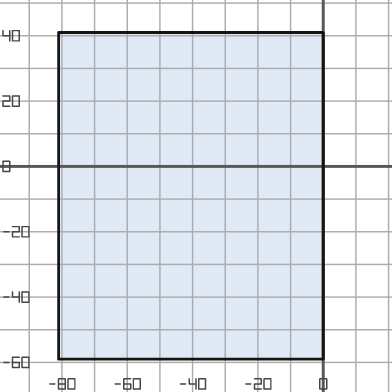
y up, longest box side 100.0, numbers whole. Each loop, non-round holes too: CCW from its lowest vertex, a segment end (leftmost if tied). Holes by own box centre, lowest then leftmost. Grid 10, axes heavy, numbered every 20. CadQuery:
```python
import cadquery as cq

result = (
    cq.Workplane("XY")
    .moveTo(-81.0, -59.0)
    .lineTo(0.0, -59.0)
    .lineTo(0.0, 41.0)
    .lineTo(-81.0, 41.0)
    .close()
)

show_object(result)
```